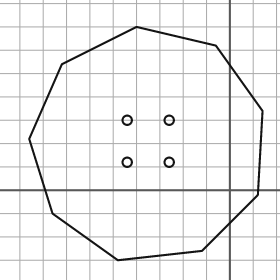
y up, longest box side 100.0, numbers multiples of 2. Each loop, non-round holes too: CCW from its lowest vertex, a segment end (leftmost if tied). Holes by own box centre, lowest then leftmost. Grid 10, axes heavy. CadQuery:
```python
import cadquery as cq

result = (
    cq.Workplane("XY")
    .moveTo(-48.0, -30.0)
    .lineTo(-12.0, -26.0)
    .lineTo(12.0, -2.0)
    .lineTo(14.0, 34.0)
    .lineTo(-6.0, 62.0)
    .lineTo(-40.0, 70.0)
    .lineTo(-72.0, 54.0)
    .lineTo(-86.0, 22.0)
    .lineTo(-76.0, -10.0)
    .close()
    .moveTo(-44.0, 12.0)
    .circle(2.0)
    .moveTo(-26.0, 12.0)
    .circle(2.0)
    .moveTo(-44.0, 30.0)
    .circle(2.0)
    .moveTo(-26.0, 30.0)
    .circle(2.0)
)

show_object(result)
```